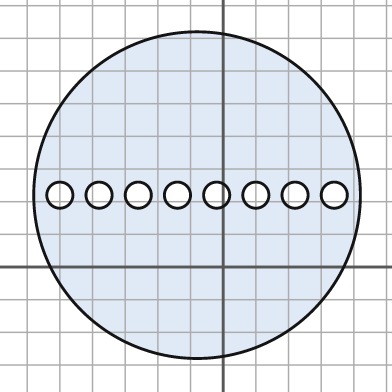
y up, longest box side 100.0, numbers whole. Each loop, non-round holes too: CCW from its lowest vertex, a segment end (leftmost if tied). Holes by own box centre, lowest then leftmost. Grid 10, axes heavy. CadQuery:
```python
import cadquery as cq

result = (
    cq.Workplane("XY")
    .moveTo(-8.0, 22.0)
    .circle(50.0)
    .moveTo(-50.0, 22.0)
    .circle(4.0)
    .moveTo(-38.0, 22.0)
    .circle(4.0)
    .moveTo(-26.0, 22.0)
    .circle(4.0)
    .moveTo(-14.0, 22.0)
    .circle(4.0)
    .moveTo(-2.0, 22.0)
    .circle(4.0)
    .moveTo(10.0, 22.0)
    .circle(4.0)
    .moveTo(22.0, 22.0)
    .circle(4.0)
    .moveTo(34.0, 22.0)
    .circle(4.0)
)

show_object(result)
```